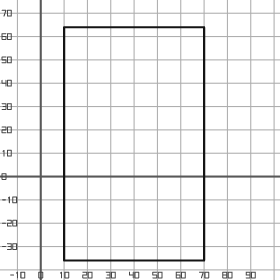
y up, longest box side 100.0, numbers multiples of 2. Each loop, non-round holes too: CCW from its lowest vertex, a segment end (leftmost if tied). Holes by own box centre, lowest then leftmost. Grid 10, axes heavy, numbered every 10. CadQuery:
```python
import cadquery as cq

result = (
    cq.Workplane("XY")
    .moveTo(10.0, -36.0)
    .lineTo(70.0, -36.0)
    .lineTo(70.0, 64.0)
    .lineTo(10.0, 64.0)
    .close()
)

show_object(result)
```